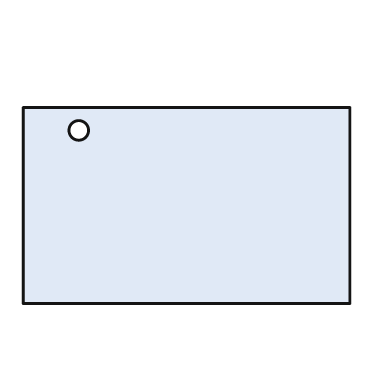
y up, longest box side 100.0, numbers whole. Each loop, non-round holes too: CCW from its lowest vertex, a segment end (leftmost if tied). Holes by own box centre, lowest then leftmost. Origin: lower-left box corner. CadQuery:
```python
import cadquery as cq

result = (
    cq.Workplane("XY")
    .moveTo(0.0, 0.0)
    .lineTo(100.0, 0.0)
    .lineTo(100.0, 60.0)
    .lineTo(0.0, 60.0)
    .close()
    .moveTo(17.0, 53.0)
    .circle(3.0)
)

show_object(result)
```